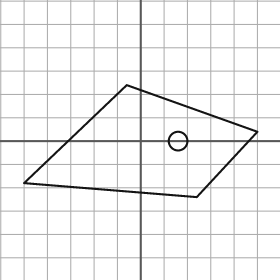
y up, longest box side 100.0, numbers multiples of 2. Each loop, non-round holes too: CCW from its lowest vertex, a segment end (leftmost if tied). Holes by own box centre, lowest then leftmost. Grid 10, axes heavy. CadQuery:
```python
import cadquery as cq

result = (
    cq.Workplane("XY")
    .moveTo(24.0, -24.0)
    .lineTo(50.0, 4.0)
    .lineTo(-6.0, 24.0)
    .lineTo(-50.0, -18.0)
    .close()
    .moveTo(16.0, 0.0)
    .circle(4.0)
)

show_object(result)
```